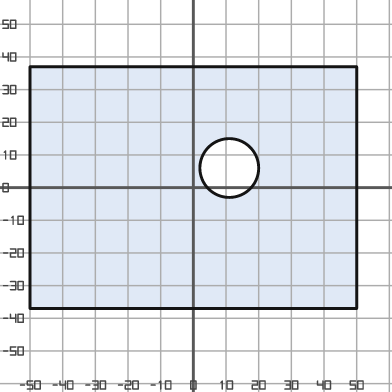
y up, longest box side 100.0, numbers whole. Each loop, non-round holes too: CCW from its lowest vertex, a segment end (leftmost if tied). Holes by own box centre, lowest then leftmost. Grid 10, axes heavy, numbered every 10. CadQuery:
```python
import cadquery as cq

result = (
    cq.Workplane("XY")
    .moveTo(-50.0, -37.0)
    .lineTo(50.0, -37.0)
    .lineTo(50.0, 37.0)
    .lineTo(-50.0, 37.0)
    .close()
    .moveTo(11.0, 6.0)
    .circle(9.0)
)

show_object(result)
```